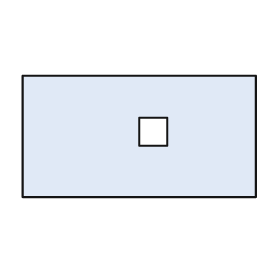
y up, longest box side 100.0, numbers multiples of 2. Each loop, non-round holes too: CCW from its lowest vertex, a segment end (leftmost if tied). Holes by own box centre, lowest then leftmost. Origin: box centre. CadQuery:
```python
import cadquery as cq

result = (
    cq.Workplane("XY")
    .moveTo(-50.0, -26.0)
    .lineTo(50.0, -26.0)
    .lineTo(50.0, 26.0)
    .lineTo(-50.0, 26.0)
    .close()
    .moveTo(0.0, -4.0)
    .lineTo(12.0, -4.0)
    .lineTo(12.0, 8.0)
    .lineTo(0.0, 8.0)
    .close()
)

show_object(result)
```